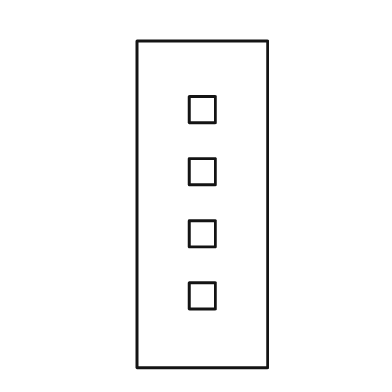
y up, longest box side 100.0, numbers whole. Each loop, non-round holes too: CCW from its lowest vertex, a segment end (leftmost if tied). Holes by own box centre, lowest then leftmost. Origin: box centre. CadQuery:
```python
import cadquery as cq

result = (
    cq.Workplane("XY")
    .moveTo(-20.0, -50.0)
    .lineTo(20.0, -50.0)
    .lineTo(20.0, 50.0)
    .lineTo(-20.0, 50.0)
    .close()
    .moveTo(-4.0, -32.0)
    .lineTo(4.0, -32.0)
    .lineTo(4.0, -24.0)
    .lineTo(-4.0, -24.0)
    .close()
    .moveTo(-4.0, -13.0)
    .lineTo(4.0, -13.0)
    .lineTo(4.0, -5.0)
    .lineTo(-4.0, -5.0)
    .close()
    .moveTo(-4.0, 6.0)
    .lineTo(4.0, 6.0)
    .lineTo(4.0, 14.0)
    .lineTo(-4.0, 14.0)
    .close()
    .moveTo(-4.0, 25.0)
    .lineTo(4.0, 25.0)
    .lineTo(4.0, 33.0)
    .lineTo(-4.0, 33.0)
    .close()
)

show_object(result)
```